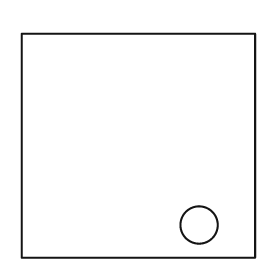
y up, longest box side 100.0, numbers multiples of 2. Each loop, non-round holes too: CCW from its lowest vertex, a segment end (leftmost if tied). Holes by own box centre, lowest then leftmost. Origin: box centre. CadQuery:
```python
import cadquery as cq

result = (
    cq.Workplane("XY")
    .moveTo(-50.0, -48.0)
    .lineTo(50.0, -48.0)
    .lineTo(50.0, 48.0)
    .lineTo(-50.0, 48.0)
    .close()
    .moveTo(26.0, -34.0)
    .circle(8.0)
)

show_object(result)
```